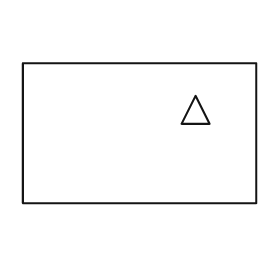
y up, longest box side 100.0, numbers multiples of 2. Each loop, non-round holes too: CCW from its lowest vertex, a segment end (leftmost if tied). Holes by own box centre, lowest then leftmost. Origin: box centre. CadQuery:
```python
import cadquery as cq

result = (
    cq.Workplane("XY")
    .moveTo(-50.0, -30.0)
    .lineTo(50.0, -30.0)
    .lineTo(50.0, 30.0)
    .lineTo(-50.0, 30.0)
    .close()
    .moveTo(18.0, 4.0)
    .lineTo(30.0, 4.0)
    .lineTo(24.0, 16.0)
    .close()
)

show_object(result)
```